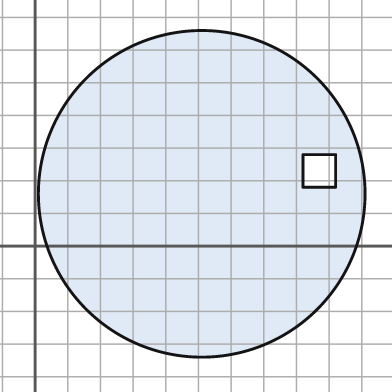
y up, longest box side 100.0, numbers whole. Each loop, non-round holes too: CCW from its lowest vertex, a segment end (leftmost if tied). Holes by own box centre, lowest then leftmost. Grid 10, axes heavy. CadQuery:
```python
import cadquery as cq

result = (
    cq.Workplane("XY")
    .moveTo(51.0, 16.0)
    .circle(50.0)
    .moveTo(82.0, 18.0)
    .lineTo(92.0, 18.0)
    .lineTo(92.0, 28.0)
    .lineTo(82.0, 28.0)
    .close()
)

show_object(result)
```